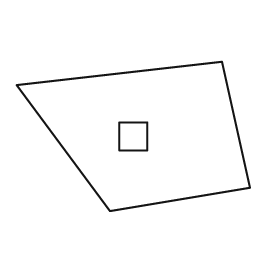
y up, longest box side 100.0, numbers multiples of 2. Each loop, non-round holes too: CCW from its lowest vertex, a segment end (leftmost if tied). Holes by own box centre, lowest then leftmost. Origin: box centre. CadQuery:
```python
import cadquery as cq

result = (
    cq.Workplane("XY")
    .moveTo(-10.0, -32.0)
    .lineTo(50.0, -22.0)
    .lineTo(38.0, 32.0)
    .lineTo(-50.0, 22.0)
    .close()
    .moveTo(-6.0, -6.0)
    .lineTo(6.0, -6.0)
    .lineTo(6.0, 6.0)
    .lineTo(-6.0, 6.0)
    .close()
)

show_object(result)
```